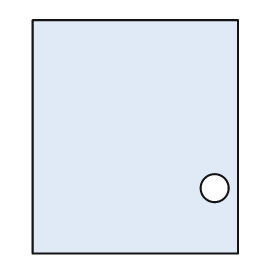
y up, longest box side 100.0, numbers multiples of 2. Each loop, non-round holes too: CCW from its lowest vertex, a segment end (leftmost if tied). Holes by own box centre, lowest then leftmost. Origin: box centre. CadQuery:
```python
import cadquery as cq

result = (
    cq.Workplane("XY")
    .moveTo(-44.0, -50.0)
    .lineTo(44.0, -50.0)
    .lineTo(44.0, 50.0)
    .lineTo(-44.0, 50.0)
    .close()
    .moveTo(34.0, -22.0)
    .circle(6.0)
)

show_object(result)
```